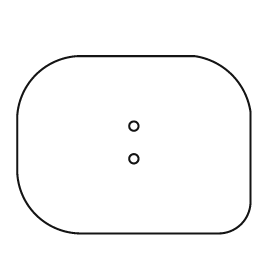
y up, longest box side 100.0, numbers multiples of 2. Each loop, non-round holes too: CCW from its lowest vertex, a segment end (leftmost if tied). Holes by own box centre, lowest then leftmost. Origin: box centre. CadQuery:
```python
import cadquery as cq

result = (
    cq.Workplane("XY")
    .moveTo(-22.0, -38.0)
    .lineTo(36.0, -38.0)
    .threePointArc((46.0, -34.0), (50.0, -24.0))
    .lineTo(50.0, 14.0)
    .threePointArc((42.0, 30.0), (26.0, 38.0))
    .lineTo(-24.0, 38.0)
    .threePointArc((-42.0, 30.0), (-50.0, 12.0))
    .lineTo(-50.0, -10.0)
    .threePointArc((-42.0, -30.0), (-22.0, -38.0))
    .close()
    .moveTo(0.0, -6.0)
    .circle(2.0)
    .moveTo(0.0, 8.0)
    .circle(2.0)
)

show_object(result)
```